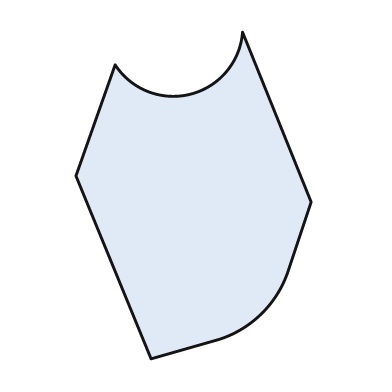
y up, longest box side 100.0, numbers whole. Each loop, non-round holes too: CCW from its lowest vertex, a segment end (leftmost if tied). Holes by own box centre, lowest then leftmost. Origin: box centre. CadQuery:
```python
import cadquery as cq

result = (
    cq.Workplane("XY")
    .moveTo(-13.0, -50.0)
    .lineTo(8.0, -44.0)
    .threePointArc((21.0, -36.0), (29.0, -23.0))
    .lineTo(36.0, -2.0)
    .lineTo(15.0, 50.0)
    .threePointArc((-1.0, 31.0), (-24.0, 40.0))
    .lineTo(-36.0, 6.0)
    .close()
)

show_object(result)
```